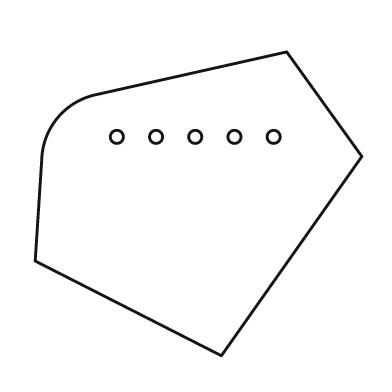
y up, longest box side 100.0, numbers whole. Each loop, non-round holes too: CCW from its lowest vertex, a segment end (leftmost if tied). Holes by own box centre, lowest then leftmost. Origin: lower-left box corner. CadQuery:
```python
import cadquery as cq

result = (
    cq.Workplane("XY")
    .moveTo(57.0, 0.0)
    .lineTo(100.0, 61.0)
    .lineTo(77.0, 93.0)
    .lineTo(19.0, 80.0)
    .threePointArc((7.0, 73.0), (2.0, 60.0))
    .lineTo(0.0, 29.0)
    .close()
    .moveTo(25.0, 67.0)
    .circle(2.0)
    .moveTo(37.0, 67.0)
    .circle(2.0)
    .moveTo(49.0, 67.0)
    .circle(2.0)
    .moveTo(61.0, 67.0)
    .circle(2.0)
    .moveTo(73.0, 67.0)
    .circle(2.0)
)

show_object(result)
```